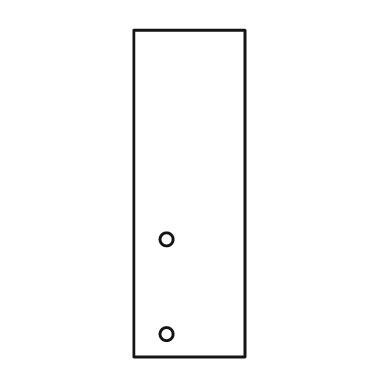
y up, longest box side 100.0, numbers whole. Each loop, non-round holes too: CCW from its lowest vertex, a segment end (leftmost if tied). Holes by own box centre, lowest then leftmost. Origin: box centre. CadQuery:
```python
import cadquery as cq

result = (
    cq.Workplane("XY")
    .moveTo(-17.0, -50.0)
    .lineTo(17.0, -50.0)
    .lineTo(17.0, 50.0)
    .lineTo(-17.0, 50.0)
    .close()
    .moveTo(-7.0, -43.0)
    .circle(2.0)
    .moveTo(-7.0, -14.0)
    .circle(2.0)
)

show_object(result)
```